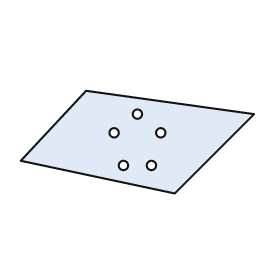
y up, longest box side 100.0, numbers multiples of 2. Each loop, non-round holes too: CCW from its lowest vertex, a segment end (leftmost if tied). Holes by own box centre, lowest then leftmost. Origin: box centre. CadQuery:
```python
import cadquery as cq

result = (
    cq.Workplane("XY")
    .moveTo(16.0, -22.0)
    .lineTo(50.0, 12.0)
    .lineTo(-22.0, 22.0)
    .lineTo(-50.0, -8.0)
    .close()
    .moveTo(-6.0, -10.0)
    .circle(2.0)
    .moveTo(6.0, -10.0)
    .circle(2.0)
    .moveTo(-10.0, 4.0)
    .circle(2.0)
    .moveTo(10.0, 4.0)
    .circle(2.0)
    .moveTo(0.0, 12.0)
    .circle(2.0)
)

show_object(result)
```